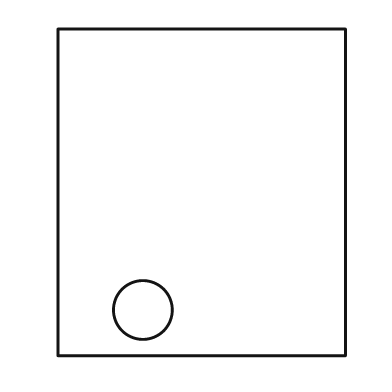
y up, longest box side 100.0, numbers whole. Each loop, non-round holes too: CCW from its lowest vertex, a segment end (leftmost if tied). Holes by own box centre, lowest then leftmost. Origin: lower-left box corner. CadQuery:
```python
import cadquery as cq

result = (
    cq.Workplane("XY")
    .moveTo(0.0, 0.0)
    .lineTo(88.0, 0.0)
    .lineTo(88.0, 100.0)
    .lineTo(0.0, 100.0)
    .close()
    .moveTo(26.0, 14.0)
    .circle(9.0)
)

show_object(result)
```